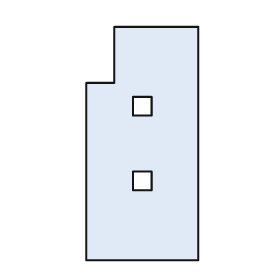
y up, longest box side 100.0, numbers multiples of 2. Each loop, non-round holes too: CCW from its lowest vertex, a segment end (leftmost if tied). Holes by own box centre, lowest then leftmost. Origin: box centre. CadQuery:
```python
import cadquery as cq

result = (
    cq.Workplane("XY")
    .moveTo(-24.0, -50.0)
    .lineTo(24.0, -50.0)
    .lineTo(24.0, 50.0)
    .lineTo(-12.0, 50.0)
    .lineTo(-12.0, 26.0)
    .lineTo(-24.0, 26.0)
    .close()
    .moveTo(-4.0, -20.0)
    .lineTo(4.0, -20.0)
    .lineTo(4.0, -12.0)
    .lineTo(-4.0, -12.0)
    .close()
    .moveTo(-4.0, 12.0)
    .lineTo(4.0, 12.0)
    .lineTo(4.0, 20.0)
    .lineTo(-4.0, 20.0)
    .close()
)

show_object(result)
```